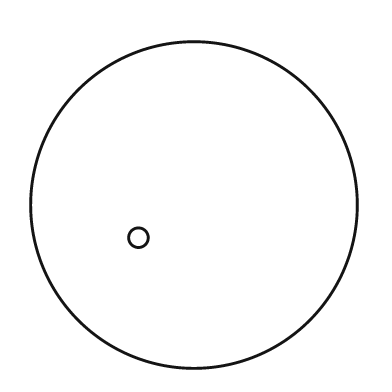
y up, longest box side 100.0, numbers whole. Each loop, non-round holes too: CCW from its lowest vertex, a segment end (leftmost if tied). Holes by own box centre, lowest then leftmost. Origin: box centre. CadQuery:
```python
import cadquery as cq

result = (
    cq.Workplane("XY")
    .moveTo(0.0, 0.0)
    .circle(50.0)
    .moveTo(-17.0, -10.0)
    .circle(3.0)
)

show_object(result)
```